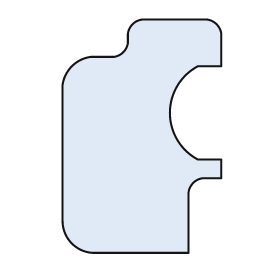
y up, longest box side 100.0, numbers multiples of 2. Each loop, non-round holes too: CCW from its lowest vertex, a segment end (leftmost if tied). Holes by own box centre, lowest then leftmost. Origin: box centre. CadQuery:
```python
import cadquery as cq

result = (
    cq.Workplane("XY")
    .moveTo(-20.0, -50.0)
    .lineTo(20.0, -50.0)
    .lineTo(20.0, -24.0)
    .threePointArc((22.0, -20.0), (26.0, -18.0))
    .lineTo(34.0, -18.0)
    .lineTo(34.0, -10.0)
    .lineTo(24.0, -10.0)
    .threePointArc((12.0, 10.0), (24.0, 30.0))
    .lineTo(34.0, 30.0)
    .lineTo(34.0, 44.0)
    .threePointArc((32.0, 48.0), (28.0, 50.0))
    .lineTo(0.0, 50.0)
    .threePointArc((-4.0, 48.0), (-6.0, 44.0))
    .lineTo(-6.0, 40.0)
    .threePointArc((-8.0, 36.0), (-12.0, 34.0))
    .lineTo(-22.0, 34.0)
    .threePointArc((-30.0, 30.0), (-34.0, 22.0))
    .lineTo(-34.0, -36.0)
    .threePointArc((-30.0, -46.0), (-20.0, -50.0))
    .close()
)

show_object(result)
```